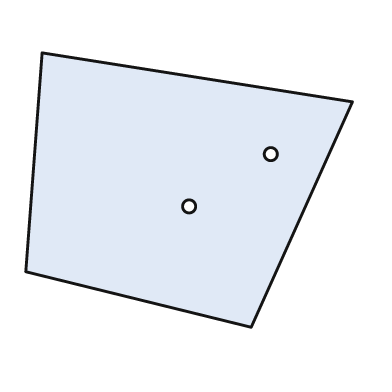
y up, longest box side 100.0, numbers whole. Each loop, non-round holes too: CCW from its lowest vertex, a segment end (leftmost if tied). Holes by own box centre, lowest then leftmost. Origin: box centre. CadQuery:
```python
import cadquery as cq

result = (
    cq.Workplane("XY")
    .moveTo(19.0, -42.0)
    .lineTo(50.0, 27.0)
    .lineTo(-45.0, 42.0)
    .lineTo(-50.0, -25.0)
    .close()
    .moveTo(0.0, -5.0)
    .circle(2.0)
    .moveTo(25.0, 11.0)
    .circle(2.0)
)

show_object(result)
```